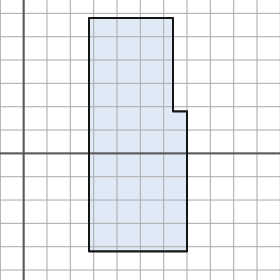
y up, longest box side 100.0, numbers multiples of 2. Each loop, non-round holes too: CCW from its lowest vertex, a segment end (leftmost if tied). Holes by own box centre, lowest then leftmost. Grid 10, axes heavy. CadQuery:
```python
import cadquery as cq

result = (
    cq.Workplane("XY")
    .moveTo(28.0, -42.0)
    .lineTo(70.0, -42.0)
    .lineTo(70.0, 18.0)
    .lineTo(64.0, 18.0)
    .lineTo(64.0, 58.0)
    .lineTo(28.0, 58.0)
    .close()
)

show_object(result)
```